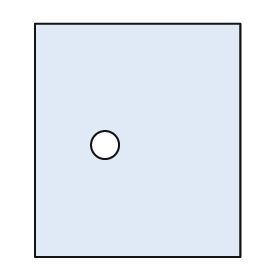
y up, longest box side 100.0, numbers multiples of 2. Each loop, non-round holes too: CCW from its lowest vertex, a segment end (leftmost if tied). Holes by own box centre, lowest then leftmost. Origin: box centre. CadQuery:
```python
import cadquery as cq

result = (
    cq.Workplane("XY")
    .moveTo(-44.0, -50.0)
    .lineTo(44.0, -50.0)
    .lineTo(44.0, 50.0)
    .lineTo(-44.0, 50.0)
    .close()
    .moveTo(-14.0, -2.0)
    .circle(6.0)
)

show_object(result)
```